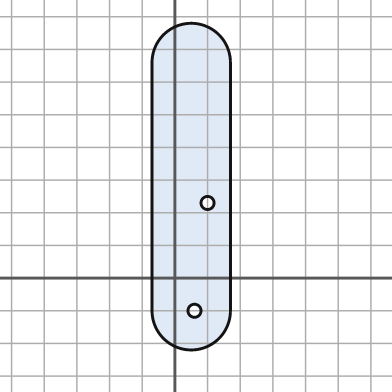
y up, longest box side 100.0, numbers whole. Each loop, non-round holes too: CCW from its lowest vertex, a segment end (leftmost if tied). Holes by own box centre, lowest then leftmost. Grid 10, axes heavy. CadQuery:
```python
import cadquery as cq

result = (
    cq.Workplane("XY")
    .moveTo(-7.0, -10.0)
    .threePointArc((5.0, -22.0), (17.0, -10.0))
    .lineTo(17.0, 66.0)
    .threePointArc((5.0, 78.0), (-7.0, 66.0))
    .close()
    .moveTo(6.0, -10.0)
    .circle(2.0)
    .moveTo(10.0, 23.0)
    .circle(2.0)
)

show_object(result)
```